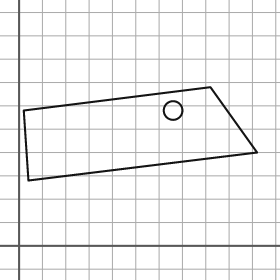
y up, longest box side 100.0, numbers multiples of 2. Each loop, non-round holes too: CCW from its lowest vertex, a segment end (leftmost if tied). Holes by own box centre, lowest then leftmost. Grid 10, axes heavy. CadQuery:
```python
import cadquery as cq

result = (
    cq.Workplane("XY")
    .moveTo(4.0, 28.0)
    .lineTo(102.0, 40.0)
    .lineTo(82.0, 68.0)
    .lineTo(2.0, 58.0)
    .close()
    .moveTo(66.0, 58.0)
    .circle(4.0)
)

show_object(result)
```